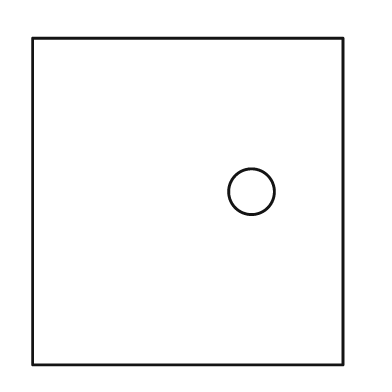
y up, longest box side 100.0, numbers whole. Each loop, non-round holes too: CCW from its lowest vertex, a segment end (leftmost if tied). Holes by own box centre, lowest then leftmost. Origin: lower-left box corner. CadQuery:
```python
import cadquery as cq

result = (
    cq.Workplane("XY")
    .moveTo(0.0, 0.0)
    .lineTo(95.0, 0.0)
    .lineTo(95.0, 100.0)
    .lineTo(0.0, 100.0)
    .close()
    .moveTo(67.0, 53.0)
    .circle(7.0)
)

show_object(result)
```